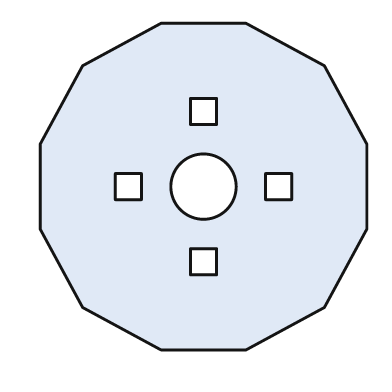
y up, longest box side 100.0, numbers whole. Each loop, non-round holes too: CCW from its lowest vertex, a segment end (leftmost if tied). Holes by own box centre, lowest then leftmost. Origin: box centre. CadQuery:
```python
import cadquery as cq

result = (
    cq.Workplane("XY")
    .moveTo(-13.0, -50.0)
    .lineTo(13.0, -50.0)
    .lineTo(37.0, -37.0)
    .lineTo(50.0, -13.0)
    .lineTo(50.0, 13.0)
    .lineTo(37.0, 37.0)
    .lineTo(13.0, 50.0)
    .lineTo(-13.0, 50.0)
    .lineTo(-37.0, 37.0)
    .lineTo(-50.0, 13.0)
    .lineTo(-50.0, -13.0)
    .lineTo(-37.0, -37.0)
    .close()
    .moveTo(-4.0, -27.0)
    .lineTo(4.0, -27.0)
    .lineTo(4.0, -19.0)
    .lineTo(-4.0, -19.0)
    .close()
    .moveTo(-27.0, -4.0)
    .lineTo(-19.0, -4.0)
    .lineTo(-19.0, 4.0)
    .lineTo(-27.0, 4.0)
    .close()
    .moveTo(0.0, 0.0)
    .circle(10.0)
    .moveTo(19.0, -4.0)
    .lineTo(27.0, -4.0)
    .lineTo(27.0, 4.0)
    .lineTo(19.0, 4.0)
    .close()
    .moveTo(-4.0, 19.0)
    .lineTo(4.0, 19.0)
    .lineTo(4.0, 27.0)
    .lineTo(-4.0, 27.0)
    .close()
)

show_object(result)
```